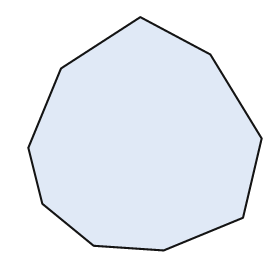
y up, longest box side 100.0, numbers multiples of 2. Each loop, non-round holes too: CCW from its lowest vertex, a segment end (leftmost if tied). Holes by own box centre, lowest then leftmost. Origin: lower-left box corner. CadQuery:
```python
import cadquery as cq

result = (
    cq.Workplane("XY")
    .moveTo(58.0, 0.0)
    .lineTo(92.0, 14.0)
    .lineTo(100.0, 48.0)
    .lineTo(78.0, 84.0)
    .lineTo(48.0, 100.0)
    .lineTo(14.0, 78.0)
    .lineTo(0.0, 44.0)
    .lineTo(6.0, 20.0)
    .lineTo(28.0, 2.0)
    .close()
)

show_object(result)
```